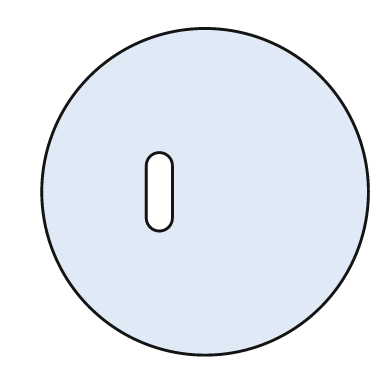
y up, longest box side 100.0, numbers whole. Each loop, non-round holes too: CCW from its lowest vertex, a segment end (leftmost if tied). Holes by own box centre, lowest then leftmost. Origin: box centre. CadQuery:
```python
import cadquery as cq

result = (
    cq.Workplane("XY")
    .moveTo(0.0, 0.0)
    .circle(50.0)
    .moveTo(-18.0, -8.0)
    .threePointArc((-14.0, -12.0), (-10.0, -8.0))
    .lineTo(-10.0, 8.0)
    .threePointArc((-14.0, 12.0), (-18.0, 8.0))
    .close()
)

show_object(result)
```